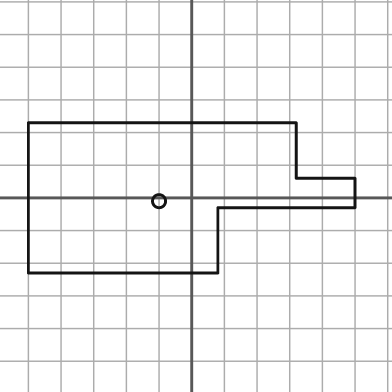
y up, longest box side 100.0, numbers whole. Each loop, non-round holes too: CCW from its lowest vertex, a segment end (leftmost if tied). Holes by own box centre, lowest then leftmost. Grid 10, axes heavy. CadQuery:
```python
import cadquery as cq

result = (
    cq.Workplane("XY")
    .moveTo(-50.0, -23.0)
    .lineTo(8.0, -23.0)
    .lineTo(8.0, -3.0)
    .lineTo(50.0, -3.0)
    .lineTo(50.0, 6.0)
    .lineTo(32.0, 6.0)
    .lineTo(32.0, 23.0)
    .lineTo(-50.0, 23.0)
    .close()
    .moveTo(-10.0, -1.0)
    .circle(2.0)
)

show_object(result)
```